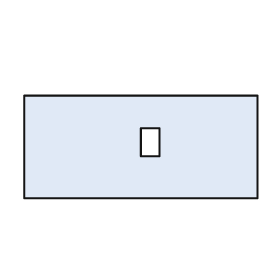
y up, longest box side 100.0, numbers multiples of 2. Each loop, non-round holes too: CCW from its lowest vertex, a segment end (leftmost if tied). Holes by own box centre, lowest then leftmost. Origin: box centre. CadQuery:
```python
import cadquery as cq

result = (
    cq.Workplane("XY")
    .moveTo(-50.0, -22.0)
    .lineTo(50.0, -22.0)
    .lineTo(50.0, 22.0)
    .lineTo(-50.0, 22.0)
    .close()
    .moveTo(0.0, -4.0)
    .lineTo(8.0, -4.0)
    .lineTo(8.0, 8.0)
    .lineTo(0.0, 8.0)
    .close()
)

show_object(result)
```